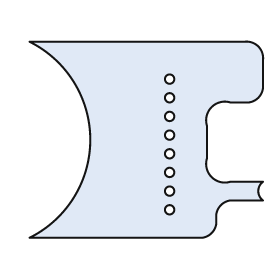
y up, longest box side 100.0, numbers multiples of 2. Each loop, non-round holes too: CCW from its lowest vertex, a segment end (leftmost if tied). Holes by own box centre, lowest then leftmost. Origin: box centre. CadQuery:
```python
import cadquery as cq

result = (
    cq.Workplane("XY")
    .moveTo(-50.0, -42.0)
    .lineTo(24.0, -42.0)
    .threePointArc((28.0, -40.0), (30.0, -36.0))
    .lineTo(30.0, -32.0)
    .threePointArc((32.0, -28.0), (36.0, -26.0))
    .lineTo(50.0, -26.0)
    .threePointArc((48.0, -22.0), (50.0, -18.0))
    .lineTo(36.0, -18.0)
    .threePointArc((28.0, -16.0), (26.0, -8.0))
    .lineTo(26.0, 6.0)
    .threePointArc((28.0, 14.0), (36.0, 16.0))
    .lineTo(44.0, 16.0)
    .threePointArc((48.0, 18.0), (50.0, 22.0))
    .lineTo(50.0, 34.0)
    .threePointArc((48.0, 40.0), (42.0, 42.0))
    .lineTo(-50.0, 42.0)
    .threePointArc((-24.0, 0.0), (-50.0, -42.0))
    .close()
    .moveTo(10.0, -30.0)
    .circle(2.0)
    .moveTo(10.0, -22.0)
    .circle(2.0)
    .moveTo(10.0, -14.0)
    .circle(2.0)
    .moveTo(10.0, -6.0)
    .circle(2.0)
    .moveTo(10.0, 2.0)
    .circle(2.0)
    .moveTo(10.0, 10.0)
    .circle(2.0)
    .moveTo(10.0, 18.0)
    .circle(2.0)
    .moveTo(10.0, 26.0)
    .circle(2.0)
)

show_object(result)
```